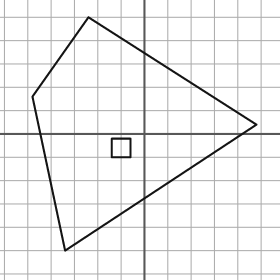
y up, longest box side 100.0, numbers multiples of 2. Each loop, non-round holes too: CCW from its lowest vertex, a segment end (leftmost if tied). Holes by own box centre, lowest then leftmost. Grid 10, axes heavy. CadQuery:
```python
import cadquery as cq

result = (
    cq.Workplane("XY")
    .moveTo(-34.0, -50.0)
    .lineTo(48.0, 4.0)
    .lineTo(-24.0, 50.0)
    .lineTo(-48.0, 16.0)
    .close()
    .moveTo(-14.0, -10.0)
    .lineTo(-6.0, -10.0)
    .lineTo(-6.0, -2.0)
    .lineTo(-14.0, -2.0)
    .close()
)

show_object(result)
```